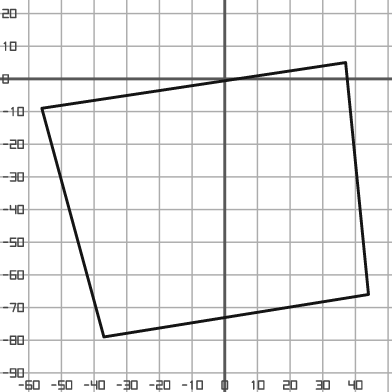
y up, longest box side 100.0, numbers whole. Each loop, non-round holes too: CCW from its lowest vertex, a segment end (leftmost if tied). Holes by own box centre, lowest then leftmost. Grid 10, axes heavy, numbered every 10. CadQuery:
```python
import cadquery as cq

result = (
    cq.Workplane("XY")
    .moveTo(-37.0, -79.0)
    .lineTo(44.0, -66.0)
    .lineTo(37.0, 5.0)
    .lineTo(-56.0, -9.0)
    .close()
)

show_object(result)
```